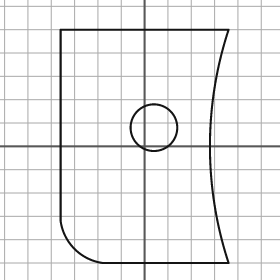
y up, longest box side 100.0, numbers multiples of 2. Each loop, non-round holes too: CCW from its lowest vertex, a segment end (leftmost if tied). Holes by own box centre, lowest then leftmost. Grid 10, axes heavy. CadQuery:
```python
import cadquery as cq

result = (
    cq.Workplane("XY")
    .moveTo(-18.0, -50.0)
    .lineTo(36.0, -50.0)
    .threePointArc((28.0, 0.0), (36.0, 50.0))
    .lineTo(-36.0, 50.0)
    .lineTo(-36.0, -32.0)
    .threePointArc((-30.0, -44.0), (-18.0, -50.0))
    .close()
    .moveTo(4.0, 8.0)
    .circle(10.0)
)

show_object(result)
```